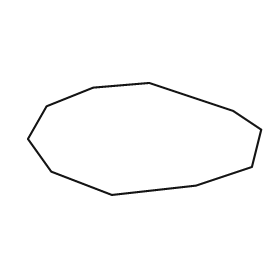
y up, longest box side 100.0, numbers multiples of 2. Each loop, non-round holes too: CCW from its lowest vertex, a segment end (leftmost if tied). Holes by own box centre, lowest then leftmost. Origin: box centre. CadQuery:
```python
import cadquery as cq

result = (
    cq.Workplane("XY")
    .moveTo(-14.0, -24.0)
    .lineTo(22.0, -20.0)
    .lineTo(46.0, -12.0)
    .lineTo(50.0, 4.0)
    .lineTo(38.0, 12.0)
    .lineTo(2.0, 24.0)
    .lineTo(-22.0, 22.0)
    .lineTo(-42.0, 14.0)
    .lineTo(-50.0, 0.0)
    .lineTo(-40.0, -14.0)
    .close()
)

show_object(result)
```